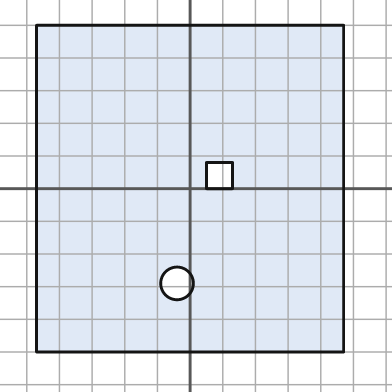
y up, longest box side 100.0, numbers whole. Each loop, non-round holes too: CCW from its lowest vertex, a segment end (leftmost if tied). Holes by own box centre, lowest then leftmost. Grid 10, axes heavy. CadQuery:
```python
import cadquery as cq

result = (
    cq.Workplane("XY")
    .moveTo(-47.0, -50.0)
    .lineTo(47.0, -50.0)
    .lineTo(47.0, 50.0)
    .lineTo(-47.0, 50.0)
    .close()
    .moveTo(-4.0, -29.0)
    .circle(5.0)
    .moveTo(5.0, 0.0)
    .lineTo(13.0, 0.0)
    .lineTo(13.0, 8.0)
    .lineTo(5.0, 8.0)
    .close()
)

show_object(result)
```